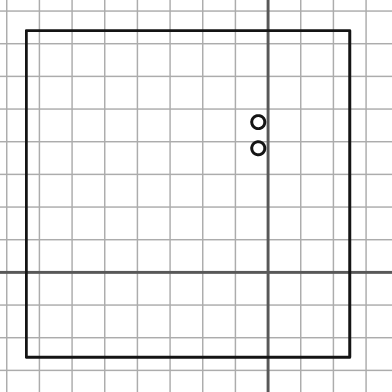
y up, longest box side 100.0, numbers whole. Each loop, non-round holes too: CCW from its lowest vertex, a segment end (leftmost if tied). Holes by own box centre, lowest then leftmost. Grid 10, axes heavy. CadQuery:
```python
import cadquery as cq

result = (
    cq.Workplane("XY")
    .moveTo(-74.0, -26.0)
    .lineTo(25.0, -26.0)
    .lineTo(25.0, 74.0)
    .lineTo(-74.0, 74.0)
    .close()
    .moveTo(-3.0, 38.0)
    .circle(2.0)
    .moveTo(-3.0, 46.0)
    .circle(2.0)
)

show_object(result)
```